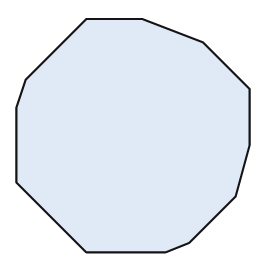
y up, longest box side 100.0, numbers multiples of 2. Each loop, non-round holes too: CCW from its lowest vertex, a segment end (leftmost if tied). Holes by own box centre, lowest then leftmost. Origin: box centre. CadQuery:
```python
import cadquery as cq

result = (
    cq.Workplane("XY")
    .moveTo(-20.0, -50.0)
    .lineTo(14.0, -50.0)
    .lineTo(24.0, -46.0)
    .lineTo(44.0, -26.0)
    .lineTo(50.0, -4.0)
    .lineTo(50.0, 20.0)
    .lineTo(30.0, 40.0)
    .lineTo(4.0, 50.0)
    .lineTo(-20.0, 50.0)
    .lineTo(-46.0, 24.0)
    .lineTo(-50.0, 12.0)
    .lineTo(-50.0, -20.0)
    .close()
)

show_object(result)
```